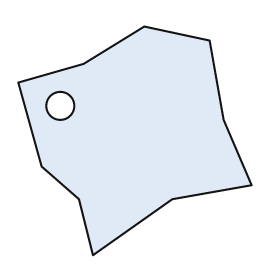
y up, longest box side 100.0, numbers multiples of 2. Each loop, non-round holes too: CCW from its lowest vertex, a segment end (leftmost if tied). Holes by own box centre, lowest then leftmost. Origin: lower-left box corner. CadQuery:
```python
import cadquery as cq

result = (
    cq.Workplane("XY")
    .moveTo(32.0, 0.0)
    .lineTo(66.0, 24.0)
    .lineTo(100.0, 30.0)
    .lineTo(88.0, 58.0)
    .lineTo(82.0, 92.0)
    .lineTo(54.0, 98.0)
    .lineTo(28.0, 82.0)
    .lineTo(0.0, 74.0)
    .lineTo(10.0, 38.0)
    .lineTo(26.0, 24.0)
    .close()
    .moveTo(18.0, 64.0)
    .circle(6.0)
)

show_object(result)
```